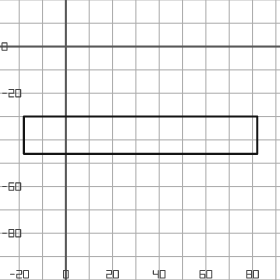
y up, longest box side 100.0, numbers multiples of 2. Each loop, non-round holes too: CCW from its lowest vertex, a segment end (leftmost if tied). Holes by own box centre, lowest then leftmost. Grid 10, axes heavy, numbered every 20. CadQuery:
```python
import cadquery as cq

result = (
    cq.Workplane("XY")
    .moveTo(-18.0, -46.0)
    .lineTo(82.0, -46.0)
    .lineTo(82.0, -30.0)
    .lineTo(-18.0, -30.0)
    .close()
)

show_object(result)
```